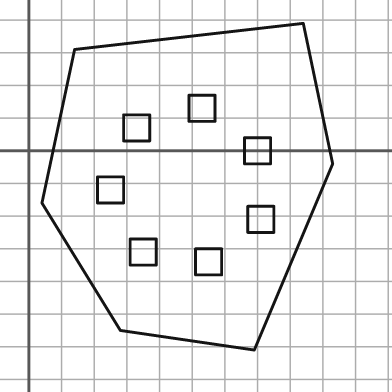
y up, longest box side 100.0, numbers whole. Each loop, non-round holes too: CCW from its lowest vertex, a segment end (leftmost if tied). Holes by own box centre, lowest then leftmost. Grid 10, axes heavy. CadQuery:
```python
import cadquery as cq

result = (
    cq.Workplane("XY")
    .moveTo(69.0, -61.0)
    .lineTo(93.0, -4.0)
    .lineTo(84.0, 39.0)
    .lineTo(14.0, 31.0)
    .lineTo(4.0, -16.0)
    .lineTo(28.0, -55.0)
    .close()
    .moveTo(51.0, -38.0)
    .lineTo(59.0, -38.0)
    .lineTo(59.0, -30.0)
    .lineTo(51.0, -30.0)
    .close()
    .moveTo(31.0, -35.0)
    .lineTo(39.0, -35.0)
    .lineTo(39.0, -27.0)
    .lineTo(31.0, -27.0)
    .close()
    .moveTo(67.0, -25.0)
    .lineTo(75.0, -25.0)
    .lineTo(75.0, -17.0)
    .lineTo(67.0, -17.0)
    .close()
    .moveTo(21.0, -16.0)
    .lineTo(29.0, -16.0)
    .lineTo(29.0, -8.0)
    .lineTo(21.0, -8.0)
    .close()
    .moveTo(66.0, -4.0)
    .lineTo(74.0, -4.0)
    .lineTo(74.0, 4.0)
    .lineTo(66.0, 4.0)
    .close()
    .moveTo(29.0, 3.0)
    .lineTo(37.0, 3.0)
    .lineTo(37.0, 11.0)
    .lineTo(29.0, 11.0)
    .close()
    .moveTo(49.0, 9.0)
    .lineTo(57.0, 9.0)
    .lineTo(57.0, 17.0)
    .lineTo(49.0, 17.0)
    .close()
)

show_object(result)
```